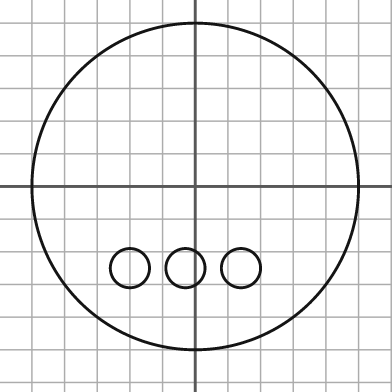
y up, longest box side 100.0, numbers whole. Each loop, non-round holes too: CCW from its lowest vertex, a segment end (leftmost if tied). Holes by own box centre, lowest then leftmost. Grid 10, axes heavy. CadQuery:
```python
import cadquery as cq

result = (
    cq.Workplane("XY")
    .moveTo(0.0, 0.0)
    .circle(50.0)
    .moveTo(-20.0, -25.0)
    .circle(6.0)
    .moveTo(-3.0, -25.0)
    .circle(6.0)
    .moveTo(14.0, -25.0)
    .circle(6.0)
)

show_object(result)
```